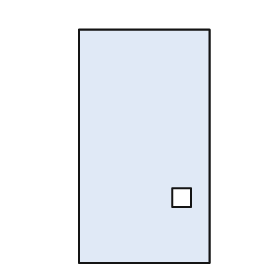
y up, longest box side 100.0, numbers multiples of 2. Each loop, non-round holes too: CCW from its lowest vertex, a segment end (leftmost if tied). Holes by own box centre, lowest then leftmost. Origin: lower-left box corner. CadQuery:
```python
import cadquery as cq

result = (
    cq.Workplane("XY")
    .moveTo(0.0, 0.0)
    .lineTo(56.0, 0.0)
    .lineTo(56.0, 100.0)
    .lineTo(0.0, 100.0)
    .close()
    .moveTo(40.0, 24.0)
    .lineTo(48.0, 24.0)
    .lineTo(48.0, 32.0)
    .lineTo(40.0, 32.0)
    .close()
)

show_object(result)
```